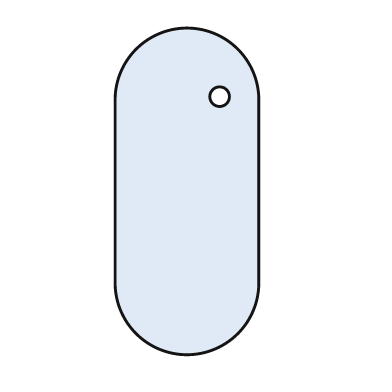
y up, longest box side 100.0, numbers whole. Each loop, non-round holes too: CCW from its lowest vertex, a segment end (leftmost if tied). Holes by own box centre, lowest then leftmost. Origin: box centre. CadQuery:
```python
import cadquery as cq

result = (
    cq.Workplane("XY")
    .moveTo(-22.0, -28.0)
    .threePointArc((0.0, -50.0), (22.0, -28.0))
    .lineTo(22.0, 28.0)
    .threePointArc((0.0, 50.0), (-22.0, 28.0))
    .close()
    .moveTo(10.0, 29.0)
    .circle(3.0)
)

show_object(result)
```